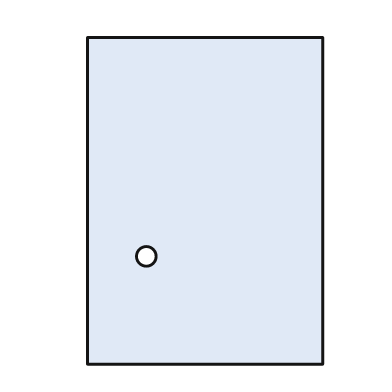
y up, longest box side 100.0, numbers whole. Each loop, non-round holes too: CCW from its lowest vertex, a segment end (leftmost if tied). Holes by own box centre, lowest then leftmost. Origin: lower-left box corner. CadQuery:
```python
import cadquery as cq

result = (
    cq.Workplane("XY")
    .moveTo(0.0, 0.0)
    .lineTo(72.0, 0.0)
    .lineTo(72.0, 100.0)
    .lineTo(0.0, 100.0)
    .close()
    .moveTo(18.0, 33.0)
    .circle(3.0)
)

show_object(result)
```